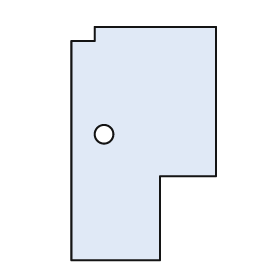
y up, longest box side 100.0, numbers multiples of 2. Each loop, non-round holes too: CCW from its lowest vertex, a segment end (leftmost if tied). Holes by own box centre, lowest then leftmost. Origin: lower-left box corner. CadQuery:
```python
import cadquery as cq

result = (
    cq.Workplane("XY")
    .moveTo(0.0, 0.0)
    .lineTo(38.0, 0.0)
    .lineTo(38.0, 36.0)
    .lineTo(62.0, 36.0)
    .lineTo(62.0, 100.0)
    .lineTo(10.0, 100.0)
    .lineTo(10.0, 94.0)
    .lineTo(0.0, 94.0)
    .close()
    .moveTo(14.0, 54.0)
    .circle(4.0)
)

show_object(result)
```